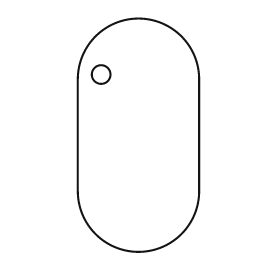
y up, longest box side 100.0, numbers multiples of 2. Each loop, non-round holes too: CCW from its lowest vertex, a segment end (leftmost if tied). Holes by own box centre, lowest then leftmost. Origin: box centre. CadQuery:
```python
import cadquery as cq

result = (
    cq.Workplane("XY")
    .moveTo(-26.0, -24.0)
    .threePointArc((0.0, -50.0), (26.0, -24.0))
    .lineTo(26.0, 24.0)
    .threePointArc((0.0, 50.0), (-26.0, 24.0))
    .close()
    .moveTo(-16.0, 26.0)
    .circle(4.0)
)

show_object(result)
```